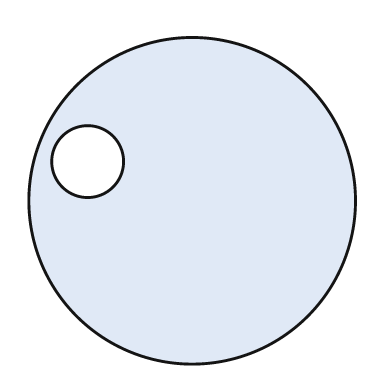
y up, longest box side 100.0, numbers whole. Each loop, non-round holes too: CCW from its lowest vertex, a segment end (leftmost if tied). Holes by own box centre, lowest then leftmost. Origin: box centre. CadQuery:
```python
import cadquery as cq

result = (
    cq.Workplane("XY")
    .moveTo(0.0, 0.0)
    .circle(50.0)
    .moveTo(-32.0, 12.0)
    .circle(11.0)
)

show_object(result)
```